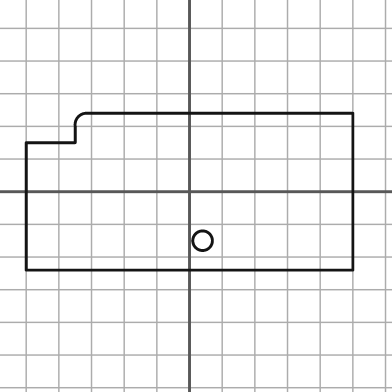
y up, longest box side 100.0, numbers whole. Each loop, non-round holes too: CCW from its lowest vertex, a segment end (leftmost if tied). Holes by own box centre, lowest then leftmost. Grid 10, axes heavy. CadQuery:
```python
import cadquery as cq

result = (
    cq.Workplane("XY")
    .moveTo(-50.0, -24.0)
    .lineTo(50.0, -24.0)
    .lineTo(50.0, 24.0)
    .lineTo(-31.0, 24.0)
    .threePointArc((-34.0, 23.0), (-35.0, 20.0))
    .lineTo(-35.0, 15.0)
    .lineTo(-50.0, 15.0)
    .close()
    .moveTo(4.0, -15.0)
    .circle(3.0)
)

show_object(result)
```